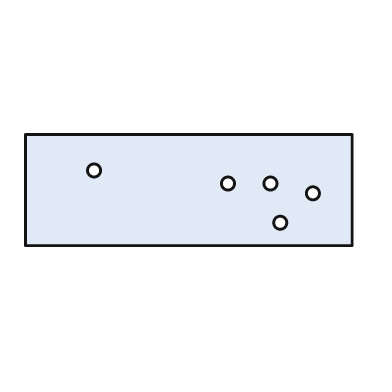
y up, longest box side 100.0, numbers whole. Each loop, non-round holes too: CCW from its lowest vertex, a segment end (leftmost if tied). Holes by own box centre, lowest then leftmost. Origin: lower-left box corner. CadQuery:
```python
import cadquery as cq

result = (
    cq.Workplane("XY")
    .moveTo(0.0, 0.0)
    .lineTo(100.0, 0.0)
    .lineTo(100.0, 34.0)
    .lineTo(0.0, 34.0)
    .close()
    .moveTo(78.0, 7.0)
    .circle(2.0)
    .moveTo(88.0, 16.0)
    .circle(2.0)
    .moveTo(62.0, 19.0)
    .circle(2.0)
    .moveTo(75.0, 19.0)
    .circle(2.0)
    .moveTo(21.0, 23.0)
    .circle(2.0)
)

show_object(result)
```